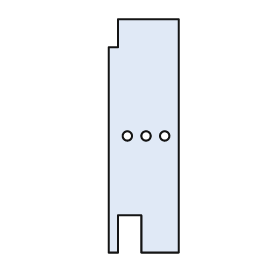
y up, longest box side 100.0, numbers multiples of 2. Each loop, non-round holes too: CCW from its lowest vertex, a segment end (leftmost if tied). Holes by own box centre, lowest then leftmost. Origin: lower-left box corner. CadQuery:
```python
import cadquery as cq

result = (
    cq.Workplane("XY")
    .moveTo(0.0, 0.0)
    .lineTo(4.0, 0.0)
    .lineTo(4.0, 16.0)
    .lineTo(14.0, 16.0)
    .lineTo(14.0, 0.0)
    .lineTo(30.0, 0.0)
    .lineTo(30.0, 100.0)
    .lineTo(4.0, 100.0)
    .lineTo(4.0, 88.0)
    .lineTo(0.0, 88.0)
    .close()
    .moveTo(8.0, 50.0)
    .circle(2.0)
    .moveTo(16.0, 50.0)
    .circle(2.0)
    .moveTo(24.0, 50.0)
    .circle(2.0)
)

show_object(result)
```